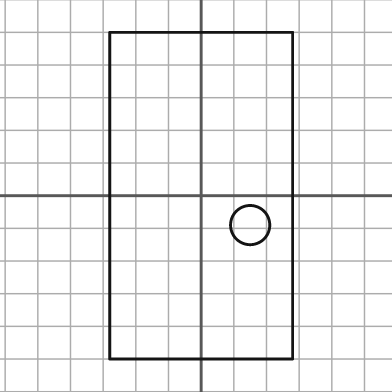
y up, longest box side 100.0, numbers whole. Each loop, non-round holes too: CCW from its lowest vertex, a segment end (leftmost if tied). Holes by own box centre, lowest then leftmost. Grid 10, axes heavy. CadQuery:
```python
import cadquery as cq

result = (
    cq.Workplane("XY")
    .moveTo(-28.0, -50.0)
    .lineTo(28.0, -50.0)
    .lineTo(28.0, 50.0)
    .lineTo(-28.0, 50.0)
    .close()
    .moveTo(15.0, -9.0)
    .circle(6.0)
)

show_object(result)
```